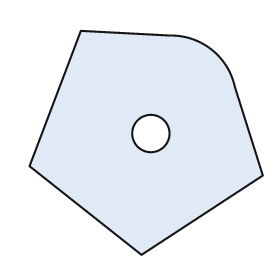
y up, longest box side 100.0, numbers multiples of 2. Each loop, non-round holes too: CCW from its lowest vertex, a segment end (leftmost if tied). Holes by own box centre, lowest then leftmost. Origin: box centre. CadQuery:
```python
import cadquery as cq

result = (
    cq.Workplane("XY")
    .moveTo(-2.0, -48.0)
    .lineTo(50.0, -14.0)
    .lineTo(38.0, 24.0)
    .threePointArc((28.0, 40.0), (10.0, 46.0))
    .lineTo(-28.0, 48.0)
    .lineTo(-50.0, -10.0)
    .close()
    .moveTo(2.0, 4.0)
    .circle(8.0)
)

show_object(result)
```